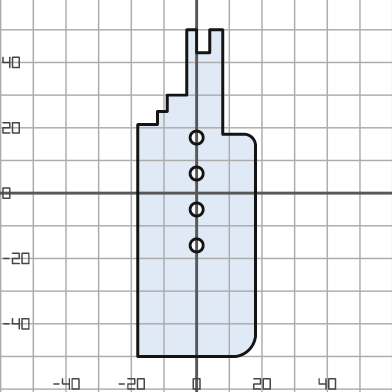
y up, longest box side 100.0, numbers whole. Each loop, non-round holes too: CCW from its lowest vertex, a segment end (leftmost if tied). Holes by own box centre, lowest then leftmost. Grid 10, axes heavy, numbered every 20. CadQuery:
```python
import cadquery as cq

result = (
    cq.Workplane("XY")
    .moveTo(-18.0, -50.0)
    .lineTo(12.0, -50.0)
    .threePointArc((16.0, -48.0), (18.0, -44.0))
    .lineTo(18.0, 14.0)
    .threePointArc((17.0, 17.0), (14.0, 18.0))
    .lineTo(8.0, 18.0)
    .lineTo(8.0, 50.0)
    .lineTo(4.0, 50.0)
    .lineTo(4.0, 43.0)
    .lineTo(0.0, 43.0)
    .lineTo(0.0, 50.0)
    .lineTo(-3.0, 50.0)
    .lineTo(-3.0, 30.0)
    .lineTo(-9.0, 30.0)
    .lineTo(-9.0, 25.0)
    .lineTo(-12.0, 25.0)
    .lineTo(-12.0, 21.0)
    .lineTo(-18.0, 21.0)
    .close()
    .moveTo(0.0, -16.0)
    .circle(2.0)
    .moveTo(0.0, -5.0)
    .circle(2.0)
    .moveTo(0.0, 6.0)
    .circle(2.0)
    .moveTo(0.0, 17.0)
    .circle(2.0)
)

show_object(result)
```